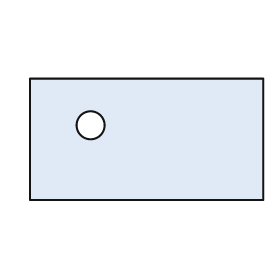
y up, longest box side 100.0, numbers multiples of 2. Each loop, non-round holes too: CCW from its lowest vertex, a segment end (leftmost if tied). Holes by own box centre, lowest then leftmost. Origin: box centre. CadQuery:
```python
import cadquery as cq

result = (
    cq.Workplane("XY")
    .moveTo(-50.0, -26.0)
    .lineTo(50.0, -26.0)
    .lineTo(50.0, 26.0)
    .lineTo(-50.0, 26.0)
    .close()
    .moveTo(-24.0, 6.0)
    .circle(6.0)
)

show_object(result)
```